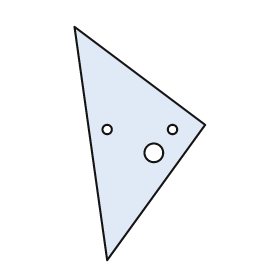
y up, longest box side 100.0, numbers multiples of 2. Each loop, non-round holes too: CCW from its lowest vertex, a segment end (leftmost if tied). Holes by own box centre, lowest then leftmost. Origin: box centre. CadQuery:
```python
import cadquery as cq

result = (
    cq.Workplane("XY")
    .moveTo(-14.0, -50.0)
    .lineTo(28.0, 8.0)
    .lineTo(-28.0, 50.0)
    .close()
    .moveTo(6.0, -4.0)
    .circle(4.0)
    .moveTo(-14.0, 6.0)
    .circle(2.0)
    .moveTo(14.0, 6.0)
    .circle(2.0)
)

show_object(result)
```